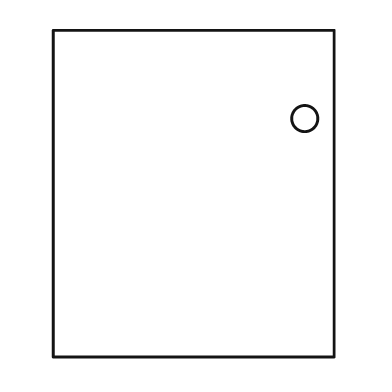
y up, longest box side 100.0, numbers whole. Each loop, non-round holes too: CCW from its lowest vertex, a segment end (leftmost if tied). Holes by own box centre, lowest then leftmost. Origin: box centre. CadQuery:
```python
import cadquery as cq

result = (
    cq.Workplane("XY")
    .moveTo(-43.0, -50.0)
    .lineTo(43.0, -50.0)
    .lineTo(43.0, 50.0)
    .lineTo(-43.0, 50.0)
    .close()
    .moveTo(34.0, 23.0)
    .circle(4.0)
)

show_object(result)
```